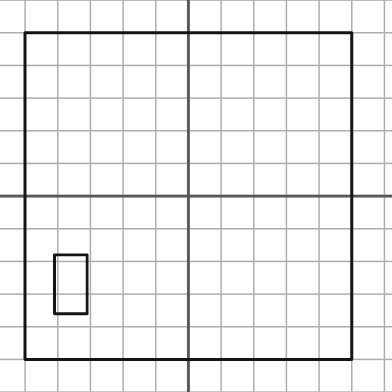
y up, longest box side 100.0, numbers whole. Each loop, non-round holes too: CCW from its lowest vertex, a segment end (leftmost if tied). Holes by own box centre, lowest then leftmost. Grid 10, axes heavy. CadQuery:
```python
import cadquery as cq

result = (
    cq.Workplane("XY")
    .moveTo(-50.0, -50.0)
    .lineTo(50.0, -50.0)
    .lineTo(50.0, 50.0)
    .lineTo(-50.0, 50.0)
    .close()
    .moveTo(-41.0, -36.0)
    .lineTo(-31.0, -36.0)
    .lineTo(-31.0, -18.0)
    .lineTo(-41.0, -18.0)
    .close()
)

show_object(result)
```